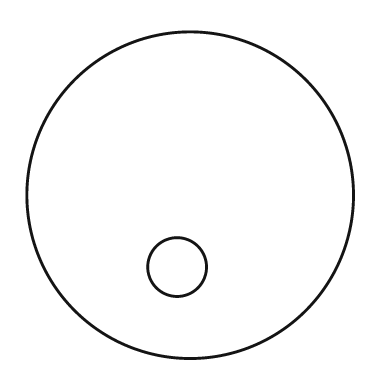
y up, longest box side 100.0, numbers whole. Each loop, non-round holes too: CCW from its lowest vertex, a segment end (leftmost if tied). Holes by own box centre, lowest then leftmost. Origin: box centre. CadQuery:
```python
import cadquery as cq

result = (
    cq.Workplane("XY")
    .moveTo(0.0, 0.0)
    .circle(50.0)
    .moveTo(-4.0, -22.0)
    .circle(9.0)
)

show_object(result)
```